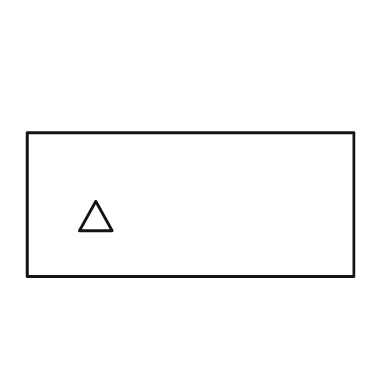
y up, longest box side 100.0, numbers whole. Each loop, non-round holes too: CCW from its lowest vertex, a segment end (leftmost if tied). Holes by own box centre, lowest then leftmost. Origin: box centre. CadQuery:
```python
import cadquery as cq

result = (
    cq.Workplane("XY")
    .moveTo(-50.0, -22.0)
    .lineTo(50.0, -22.0)
    .lineTo(50.0, 22.0)
    .lineTo(-50.0, 22.0)
    .close()
    .moveTo(-34.0, -8.0)
    .lineTo(-24.0, -8.0)
    .lineTo(-29.0, 1.0)
    .close()
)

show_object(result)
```